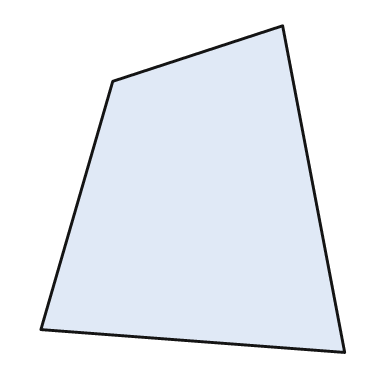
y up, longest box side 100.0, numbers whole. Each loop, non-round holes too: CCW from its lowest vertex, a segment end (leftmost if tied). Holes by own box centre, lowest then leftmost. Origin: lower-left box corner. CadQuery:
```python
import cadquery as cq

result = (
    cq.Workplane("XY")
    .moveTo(93.0, 0.0)
    .lineTo(74.0, 100.0)
    .lineTo(22.0, 83.0)
    .lineTo(0.0, 7.0)
    .close()
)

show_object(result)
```